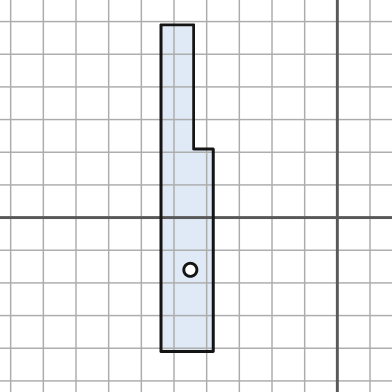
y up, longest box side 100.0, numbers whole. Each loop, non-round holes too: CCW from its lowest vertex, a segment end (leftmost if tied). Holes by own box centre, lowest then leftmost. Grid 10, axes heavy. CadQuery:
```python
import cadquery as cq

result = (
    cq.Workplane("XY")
    .moveTo(-54.0, -41.0)
    .lineTo(-38.0, -41.0)
    .lineTo(-38.0, 21.0)
    .lineTo(-44.0, 21.0)
    .lineTo(-44.0, 59.0)
    .lineTo(-54.0, 59.0)
    .close()
    .moveTo(-45.0, -16.0)
    .circle(2.0)
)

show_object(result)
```